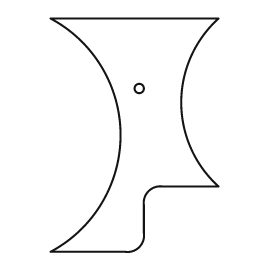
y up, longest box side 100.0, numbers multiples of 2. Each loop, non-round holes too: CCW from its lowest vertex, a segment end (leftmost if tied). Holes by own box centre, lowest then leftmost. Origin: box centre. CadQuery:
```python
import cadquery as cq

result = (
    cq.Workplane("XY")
    .moveTo(-36.0, -50.0)
    .lineTo(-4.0, -50.0)
    .threePointArc((2.0, -48.0), (4.0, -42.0))
    .lineTo(4.0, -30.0)
    .threePointArc((6.0, -24.0), (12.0, -22.0))
    .lineTo(36.0, -22.0)
    .threePointArc((20.0, 14.0), (36.0, 50.0))
    .lineTo(-36.0, 50.0)
    .threePointArc((-6.0, 0.0), (-36.0, -50.0))
    .close()
    .moveTo(2.0, 20.0)
    .circle(2.0)
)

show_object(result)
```